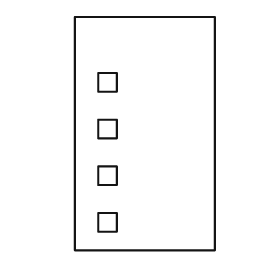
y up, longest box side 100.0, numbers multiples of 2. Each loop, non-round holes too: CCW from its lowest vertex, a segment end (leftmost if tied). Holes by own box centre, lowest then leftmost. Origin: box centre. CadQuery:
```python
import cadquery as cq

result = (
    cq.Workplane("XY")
    .moveTo(-30.0, -50.0)
    .lineTo(30.0, -50.0)
    .lineTo(30.0, 50.0)
    .lineTo(-30.0, 50.0)
    .close()
    .moveTo(-20.0, -42.0)
    .lineTo(-12.0, -42.0)
    .lineTo(-12.0, -34.0)
    .lineTo(-20.0, -34.0)
    .close()
    .moveTo(-20.0, -22.0)
    .lineTo(-12.0, -22.0)
    .lineTo(-12.0, -14.0)
    .lineTo(-20.0, -14.0)
    .close()
    .moveTo(-20.0, -2.0)
    .lineTo(-12.0, -2.0)
    .lineTo(-12.0, 6.0)
    .lineTo(-20.0, 6.0)
    .close()
    .moveTo(-20.0, 18.0)
    .lineTo(-12.0, 18.0)
    .lineTo(-12.0, 26.0)
    .lineTo(-20.0, 26.0)
    .close()
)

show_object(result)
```